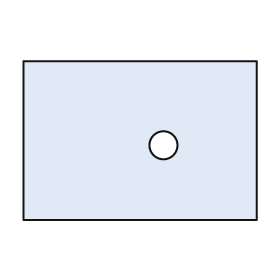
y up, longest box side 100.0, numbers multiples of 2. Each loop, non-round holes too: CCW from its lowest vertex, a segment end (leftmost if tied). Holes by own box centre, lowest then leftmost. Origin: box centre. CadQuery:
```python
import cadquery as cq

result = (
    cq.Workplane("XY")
    .moveTo(-50.0, -34.0)
    .lineTo(50.0, -34.0)
    .lineTo(50.0, 34.0)
    .lineTo(-50.0, 34.0)
    .close()
    .moveTo(10.0, -2.0)
    .circle(6.0)
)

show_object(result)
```